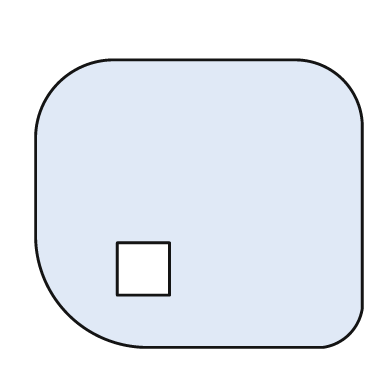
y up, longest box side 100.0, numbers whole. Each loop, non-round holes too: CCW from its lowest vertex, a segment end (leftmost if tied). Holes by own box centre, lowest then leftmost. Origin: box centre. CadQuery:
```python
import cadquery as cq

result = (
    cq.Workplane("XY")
    .moveTo(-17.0, -44.0)
    .lineTo(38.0, -44.0)
    .threePointArc((46.0, -40.0), (50.0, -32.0))
    .lineTo(50.0, 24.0)
    .threePointArc((44.0, 38.0), (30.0, 44.0))
    .lineTo(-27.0, 44.0)
    .threePointArc((-43.0, 37.0), (-50.0, 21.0))
    .lineTo(-50.0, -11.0)
    .threePointArc((-40.0, -34.0), (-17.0, -44.0))
    .close()
    .moveTo(-25.0, -28.0)
    .lineTo(-9.0, -28.0)
    .lineTo(-9.0, -12.0)
    .lineTo(-25.0, -12.0)
    .close()
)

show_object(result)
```